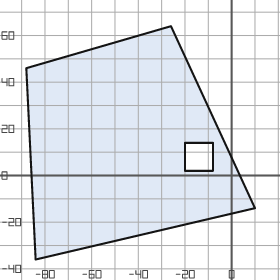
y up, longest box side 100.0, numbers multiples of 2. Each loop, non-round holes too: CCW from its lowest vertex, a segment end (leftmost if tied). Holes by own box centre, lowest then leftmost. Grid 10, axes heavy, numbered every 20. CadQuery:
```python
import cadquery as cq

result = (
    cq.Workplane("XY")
    .moveTo(-84.0, -36.0)
    .lineTo(10.0, -14.0)
    .lineTo(-26.0, 64.0)
    .lineTo(-88.0, 46.0)
    .close()
    .moveTo(-20.0, 2.0)
    .lineTo(-8.0, 2.0)
    .lineTo(-8.0, 14.0)
    .lineTo(-20.0, 14.0)
    .close()
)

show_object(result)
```